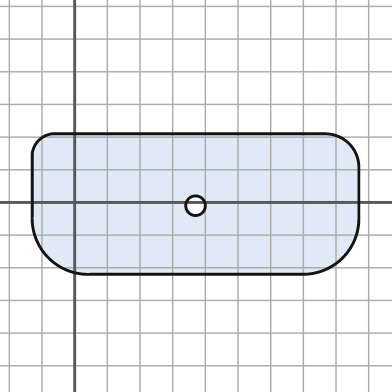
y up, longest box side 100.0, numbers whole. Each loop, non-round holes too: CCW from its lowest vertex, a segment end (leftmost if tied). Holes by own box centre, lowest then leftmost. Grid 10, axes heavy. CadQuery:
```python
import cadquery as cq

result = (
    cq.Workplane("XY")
    .moveTo(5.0, -22.0)
    .lineTo(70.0, -22.0)
    .threePointArc((82.0, -17.0), (87.0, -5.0))
    .lineTo(87.0, 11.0)
    .threePointArc((84.0, 18.0), (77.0, 21.0))
    .lineTo(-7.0, 21.0)
    .threePointArc((-11.0, 19.0), (-13.0, 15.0))
    .lineTo(-13.0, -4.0)
    .threePointArc((-8.0, -17.0), (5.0, -22.0))
    .close()
    .moveTo(37.0, -1.0)
    .circle(3.0)
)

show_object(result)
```